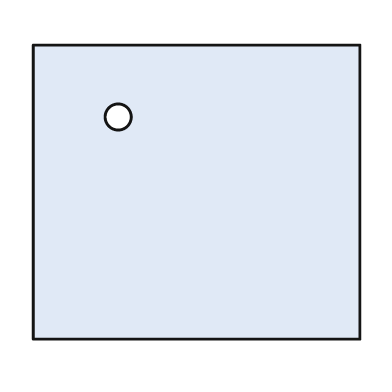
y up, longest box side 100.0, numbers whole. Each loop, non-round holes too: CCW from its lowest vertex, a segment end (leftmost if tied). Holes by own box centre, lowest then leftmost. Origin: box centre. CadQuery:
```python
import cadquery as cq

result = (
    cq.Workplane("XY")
    .moveTo(-50.0, -45.0)
    .lineTo(50.0, -45.0)
    .lineTo(50.0, 45.0)
    .lineTo(-50.0, 45.0)
    .close()
    .moveTo(-24.0, 23.0)
    .circle(4.0)
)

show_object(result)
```